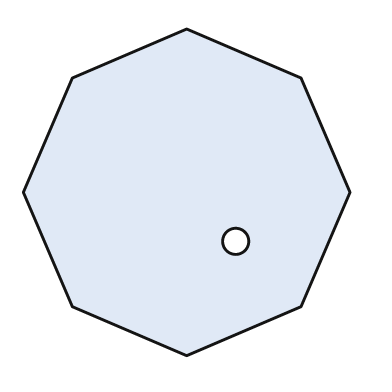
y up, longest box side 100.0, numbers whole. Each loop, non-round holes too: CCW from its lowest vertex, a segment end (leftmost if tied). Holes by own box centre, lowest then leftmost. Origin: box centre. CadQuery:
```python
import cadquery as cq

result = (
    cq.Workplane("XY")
    .moveTo(0.0, -50.0)
    .lineTo(35.0, -35.0)
    .lineTo(50.0, 0.0)
    .lineTo(35.0, 35.0)
    .lineTo(0.0, 50.0)
    .lineTo(-35.0, 35.0)
    .lineTo(-50.0, 0.0)
    .lineTo(-35.0, -35.0)
    .close()
    .moveTo(15.0, -15.0)
    .circle(4.0)
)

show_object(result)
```